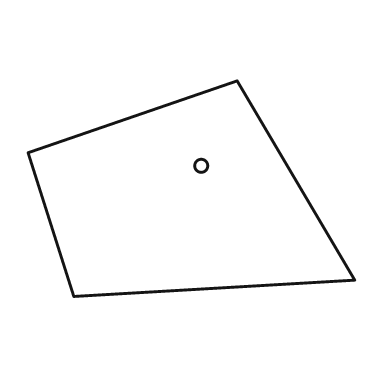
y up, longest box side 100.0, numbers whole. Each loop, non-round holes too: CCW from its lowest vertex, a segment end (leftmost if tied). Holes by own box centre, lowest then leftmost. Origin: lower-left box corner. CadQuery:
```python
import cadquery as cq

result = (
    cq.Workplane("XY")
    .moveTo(14.0, 0.0)
    .lineTo(100.0, 5.0)
    .lineTo(64.0, 66.0)
    .lineTo(0.0, 44.0)
    .close()
    .moveTo(53.0, 40.0)
    .circle(2.0)
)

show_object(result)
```